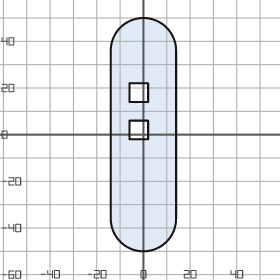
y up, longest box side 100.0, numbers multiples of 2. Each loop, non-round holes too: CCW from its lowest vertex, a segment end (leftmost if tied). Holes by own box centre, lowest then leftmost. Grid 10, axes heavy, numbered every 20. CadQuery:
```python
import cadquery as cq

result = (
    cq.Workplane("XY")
    .moveTo(-14.0, -36.0)
    .threePointArc((0.0, -50.0), (14.0, -36.0))
    .lineTo(14.0, 36.0)
    .threePointArc((0.0, 50.0), (-14.0, 36.0))
    .close()
    .moveTo(-6.0, -2.0)
    .lineTo(2.0, -2.0)
    .lineTo(2.0, 6.0)
    .lineTo(-6.0, 6.0)
    .close()
    .moveTo(-6.0, 14.0)
    .lineTo(2.0, 14.0)
    .lineTo(2.0, 22.0)
    .lineTo(-6.0, 22.0)
    .close()
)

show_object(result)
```